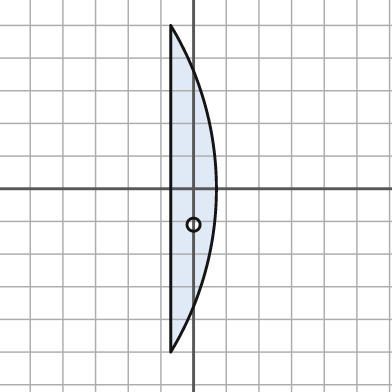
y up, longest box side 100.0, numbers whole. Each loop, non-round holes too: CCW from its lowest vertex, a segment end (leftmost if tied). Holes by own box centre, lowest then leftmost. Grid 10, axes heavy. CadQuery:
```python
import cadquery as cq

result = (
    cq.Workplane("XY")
    .moveTo(-7.0, -50.0)
    .threePointArc((7.0, 0.0), (-7.0, 50.0))
    .close()
    .moveTo(0.0, -11.0)
    .circle(2.0)
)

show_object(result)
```